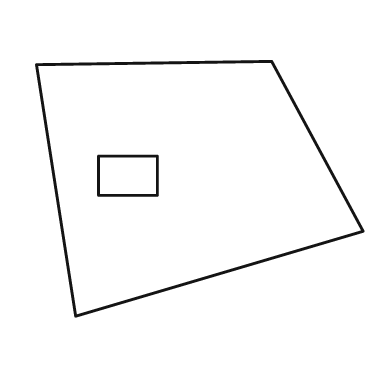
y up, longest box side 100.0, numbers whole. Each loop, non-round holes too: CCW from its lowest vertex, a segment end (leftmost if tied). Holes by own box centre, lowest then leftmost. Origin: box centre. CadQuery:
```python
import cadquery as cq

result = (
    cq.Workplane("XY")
    .moveTo(-38.0, -39.0)
    .lineTo(50.0, -13.0)
    .lineTo(22.0, 39.0)
    .lineTo(-50.0, 38.0)
    .close()
    .moveTo(-31.0, -2.0)
    .lineTo(-13.0, -2.0)
    .lineTo(-13.0, 10.0)
    .lineTo(-31.0, 10.0)
    .close()
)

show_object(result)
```